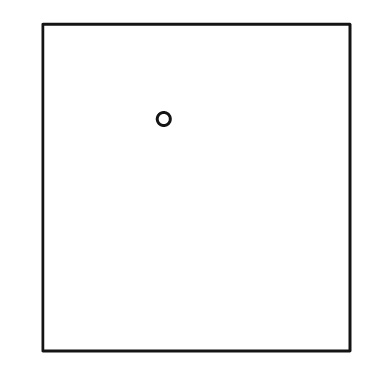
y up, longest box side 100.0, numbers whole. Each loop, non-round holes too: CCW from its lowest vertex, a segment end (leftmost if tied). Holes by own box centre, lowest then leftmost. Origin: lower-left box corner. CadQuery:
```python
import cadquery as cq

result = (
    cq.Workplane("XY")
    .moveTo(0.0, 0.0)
    .lineTo(94.0, 0.0)
    .lineTo(94.0, 100.0)
    .lineTo(0.0, 100.0)
    .close()
    .moveTo(37.0, 71.0)
    .circle(2.0)
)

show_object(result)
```